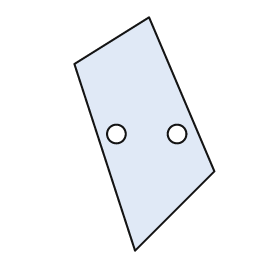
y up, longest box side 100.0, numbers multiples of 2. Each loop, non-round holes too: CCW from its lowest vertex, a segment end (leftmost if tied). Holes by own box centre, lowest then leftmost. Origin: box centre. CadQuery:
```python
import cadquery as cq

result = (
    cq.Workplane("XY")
    .moveTo(-4.0, -50.0)
    .lineTo(30.0, -16.0)
    .lineTo(2.0, 50.0)
    .lineTo(-30.0, 30.0)
    .close()
    .moveTo(-12.0, 0.0)
    .circle(4.0)
    .moveTo(14.0, 0.0)
    .circle(4.0)
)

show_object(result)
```